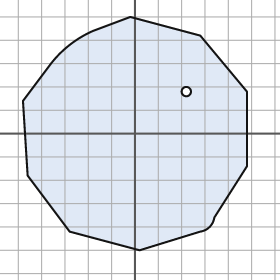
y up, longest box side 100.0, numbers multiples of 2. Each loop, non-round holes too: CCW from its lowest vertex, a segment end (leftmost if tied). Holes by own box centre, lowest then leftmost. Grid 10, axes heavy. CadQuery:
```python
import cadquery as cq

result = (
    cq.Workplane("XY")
    .moveTo(2.0, -50.0)
    .lineTo(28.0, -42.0)
    .threePointArc((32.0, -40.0), (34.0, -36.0))
    .lineTo(48.0, -14.0)
    .lineTo(48.0, 18.0)
    .lineTo(28.0, 42.0)
    .lineTo(-2.0, 50.0)
    .lineTo(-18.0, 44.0)
    .threePointArc((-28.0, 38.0), (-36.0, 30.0))
    .lineTo(-48.0, 14.0)
    .lineTo(-46.0, -18.0)
    .lineTo(-28.0, -42.0)
    .close()
    .moveTo(22.0, 18.0)
    .circle(2.0)
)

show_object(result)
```